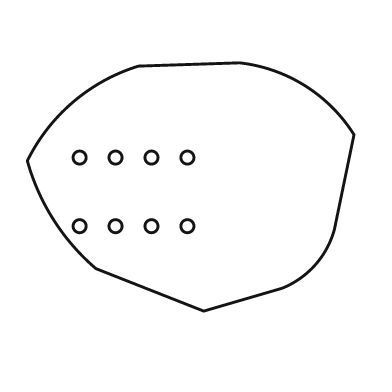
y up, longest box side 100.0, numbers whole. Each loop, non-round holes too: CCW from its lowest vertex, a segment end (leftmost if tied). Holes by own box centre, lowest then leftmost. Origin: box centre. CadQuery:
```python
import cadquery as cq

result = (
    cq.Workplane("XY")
    .moveTo(4.0, -38.0)
    .lineTo(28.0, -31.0)
    .threePointArc((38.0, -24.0), (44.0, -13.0))
    .lineTo(50.0, 16.0)
    .threePointArc((35.0, 31.0), (15.0, 38.0))
    .lineTo(-16.0, 37.0)
    .threePointArc((-36.0, 26.0), (-50.0, 8.0))
    .threePointArc((-42.0, -10.0), (-29.0, -25.0))
    .close()
    .moveTo(-34.0, -12.0)
    .circle(2.0)
    .moveTo(-23.0, -12.0)
    .circle(2.0)
    .moveTo(-12.0, -12.0)
    .circle(2.0)
    .moveTo(-1.0, -12.0)
    .circle(2.0)
    .moveTo(-34.0, 9.0)
    .circle(2.0)
    .moveTo(-23.0, 9.0)
    .circle(2.0)
    .moveTo(-12.0, 9.0)
    .circle(2.0)
    .moveTo(-1.0, 9.0)
    .circle(2.0)
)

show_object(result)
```